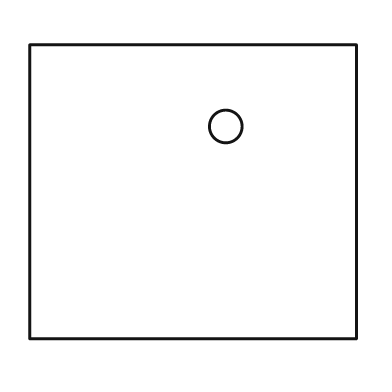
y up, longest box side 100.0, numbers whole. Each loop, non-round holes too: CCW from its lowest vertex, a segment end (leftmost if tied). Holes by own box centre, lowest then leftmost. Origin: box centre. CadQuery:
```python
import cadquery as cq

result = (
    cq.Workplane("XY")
    .moveTo(-50.0, -45.0)
    .lineTo(50.0, -45.0)
    .lineTo(50.0, 45.0)
    .lineTo(-50.0, 45.0)
    .close()
    .moveTo(10.0, 20.0)
    .circle(5.0)
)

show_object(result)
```